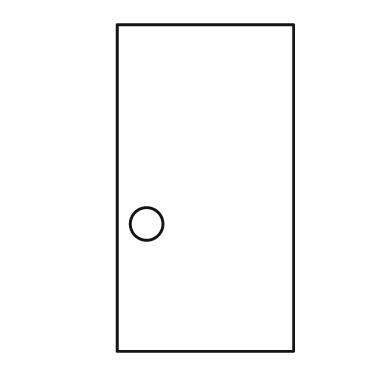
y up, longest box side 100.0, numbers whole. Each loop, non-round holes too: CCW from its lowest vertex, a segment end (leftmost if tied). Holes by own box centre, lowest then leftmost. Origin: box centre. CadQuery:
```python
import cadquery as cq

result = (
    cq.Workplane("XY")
    .moveTo(-27.0, -50.0)
    .lineTo(27.0, -50.0)
    .lineTo(27.0, 50.0)
    .lineTo(-27.0, 50.0)
    .close()
    .moveTo(-18.0, -11.0)
    .circle(5.0)
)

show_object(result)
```